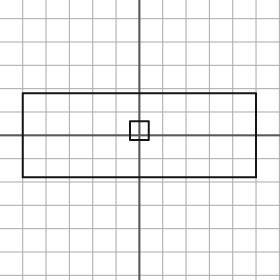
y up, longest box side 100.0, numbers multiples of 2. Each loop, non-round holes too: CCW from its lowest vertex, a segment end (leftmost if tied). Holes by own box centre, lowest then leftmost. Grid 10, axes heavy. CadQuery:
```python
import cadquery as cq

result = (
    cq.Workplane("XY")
    .moveTo(-50.0, -18.0)
    .lineTo(50.0, -18.0)
    .lineTo(50.0, 18.0)
    .lineTo(-50.0, 18.0)
    .close()
    .moveTo(-4.0, -2.0)
    .lineTo(4.0, -2.0)
    .lineTo(4.0, 6.0)
    .lineTo(-4.0, 6.0)
    .close()
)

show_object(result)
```